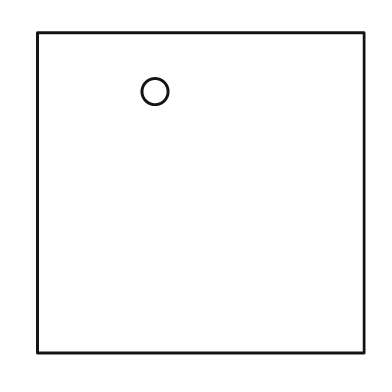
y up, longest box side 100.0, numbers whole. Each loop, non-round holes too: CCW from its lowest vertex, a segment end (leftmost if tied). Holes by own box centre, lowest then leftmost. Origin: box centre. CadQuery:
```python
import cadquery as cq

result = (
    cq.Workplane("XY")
    .moveTo(-50.0, -49.0)
    .lineTo(50.0, -49.0)
    .lineTo(50.0, 49.0)
    .lineTo(-50.0, 49.0)
    .close()
    .moveTo(-14.0, 31.0)
    .circle(4.0)
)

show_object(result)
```